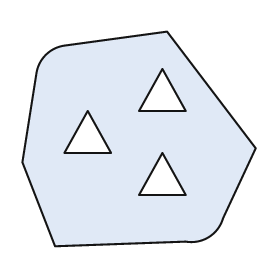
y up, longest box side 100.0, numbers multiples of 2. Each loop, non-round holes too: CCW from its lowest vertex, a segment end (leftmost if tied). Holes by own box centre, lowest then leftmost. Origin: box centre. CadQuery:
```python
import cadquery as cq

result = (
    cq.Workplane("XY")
    .moveTo(-36.0, -46.0)
    .lineTo(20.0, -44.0)
    .threePointArc((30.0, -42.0), (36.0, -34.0))
    .lineTo(50.0, -4.0)
    .lineTo(12.0, 46.0)
    .lineTo(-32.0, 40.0)
    .threePointArc((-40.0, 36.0), (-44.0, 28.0))
    .lineTo(-50.0, -10.0)
    .close()
    .moveTo(0.0, -24.0)
    .lineTo(20.0, -24.0)
    .lineTo(10.0, -6.0)
    .close()
    .moveTo(-32.0, -6.0)
    .lineTo(-12.0, -6.0)
    .lineTo(-22.0, 12.0)
    .close()
    .moveTo(0.0, 12.0)
    .lineTo(20.0, 12.0)
    .lineTo(10.0, 30.0)
    .close()
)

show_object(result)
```